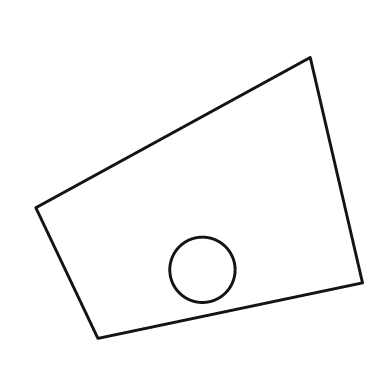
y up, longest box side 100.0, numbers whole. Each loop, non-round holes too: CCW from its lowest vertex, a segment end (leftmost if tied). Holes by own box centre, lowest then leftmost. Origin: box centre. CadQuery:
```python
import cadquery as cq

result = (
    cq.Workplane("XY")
    .moveTo(-31.0, -43.0)
    .lineTo(50.0, -26.0)
    .lineTo(34.0, 43.0)
    .lineTo(-50.0, -3.0)
    .close()
    .moveTo(1.0, -22.0)
    .circle(10.0)
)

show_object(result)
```